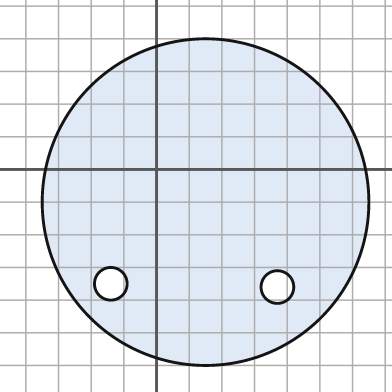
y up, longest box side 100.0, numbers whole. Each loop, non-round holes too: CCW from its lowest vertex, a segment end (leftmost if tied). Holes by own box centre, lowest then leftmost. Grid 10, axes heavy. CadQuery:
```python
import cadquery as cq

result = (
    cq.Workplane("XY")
    .moveTo(15.0, -10.0)
    .circle(50.0)
    .moveTo(37.0, -36.0)
    .circle(5.0)
    .moveTo(-14.0, -35.0)
    .circle(5.0)
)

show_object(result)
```